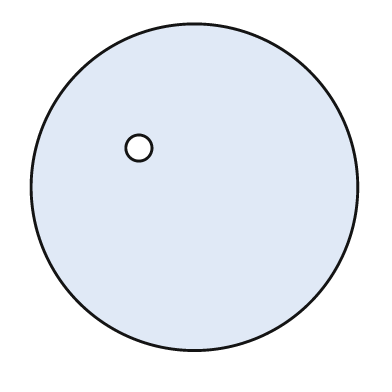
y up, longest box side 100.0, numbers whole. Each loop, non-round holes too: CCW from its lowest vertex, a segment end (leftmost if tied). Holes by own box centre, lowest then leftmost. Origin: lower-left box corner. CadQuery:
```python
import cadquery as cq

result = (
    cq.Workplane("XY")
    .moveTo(50.0, 50.0)
    .circle(50.0)
    .moveTo(33.0, 62.0)
    .circle(4.0)
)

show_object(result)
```